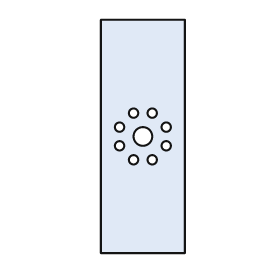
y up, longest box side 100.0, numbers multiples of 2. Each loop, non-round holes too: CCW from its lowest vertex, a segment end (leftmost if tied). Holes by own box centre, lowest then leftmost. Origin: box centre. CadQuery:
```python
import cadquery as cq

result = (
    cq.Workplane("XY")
    .moveTo(-18.0, -50.0)
    .lineTo(18.0, -50.0)
    .lineTo(18.0, 50.0)
    .lineTo(-18.0, 50.0)
    .close()
    .moveTo(-4.0, -10.0)
    .circle(2.0)
    .moveTo(4.0, -10.0)
    .circle(2.0)
    .moveTo(-10.0, -4.0)
    .circle(2.0)
    .moveTo(10.0, -4.0)
    .circle(2.0)
    .moveTo(0.0, 0.0)
    .circle(4.0)
    .moveTo(-10.0, 4.0)
    .circle(2.0)
    .moveTo(10.0, 4.0)
    .circle(2.0)
    .moveTo(-4.0, 10.0)
    .circle(2.0)
    .moveTo(4.0, 10.0)
    .circle(2.0)
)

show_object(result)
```